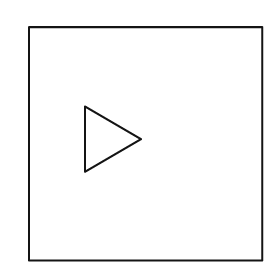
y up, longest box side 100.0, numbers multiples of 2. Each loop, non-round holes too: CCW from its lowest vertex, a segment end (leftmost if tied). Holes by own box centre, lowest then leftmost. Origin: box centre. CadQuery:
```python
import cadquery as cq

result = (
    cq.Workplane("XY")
    .moveTo(-50.0, -50.0)
    .lineTo(50.0, -50.0)
    .lineTo(50.0, 50.0)
    .lineTo(-50.0, 50.0)
    .close()
    .moveTo(-26.0, -12.0)
    .lineTo(-2.0, 2.0)
    .lineTo(-26.0, 16.0)
    .close()
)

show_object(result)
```